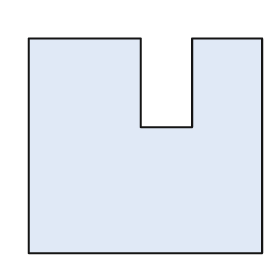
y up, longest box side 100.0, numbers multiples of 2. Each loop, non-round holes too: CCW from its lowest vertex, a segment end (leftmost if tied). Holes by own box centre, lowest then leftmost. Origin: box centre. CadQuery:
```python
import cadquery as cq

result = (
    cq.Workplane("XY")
    .moveTo(-50.0, -46.0)
    .lineTo(50.0, -46.0)
    .lineTo(50.0, 46.0)
    .lineTo(20.0, 46.0)
    .lineTo(20.0, 8.0)
    .lineTo(-2.0, 8.0)
    .lineTo(-2.0, 46.0)
    .lineTo(-50.0, 46.0)
    .close()
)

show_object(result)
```